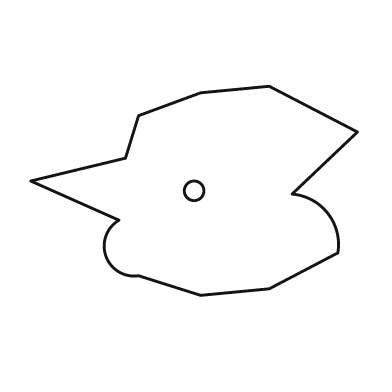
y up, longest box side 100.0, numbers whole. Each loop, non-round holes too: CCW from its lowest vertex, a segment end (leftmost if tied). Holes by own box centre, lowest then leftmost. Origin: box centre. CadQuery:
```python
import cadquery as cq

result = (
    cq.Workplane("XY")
    .moveTo(2.0, -32.0)
    .lineTo(23.0, -30.0)
    .lineTo(44.0, -19.0)
    .threePointArc((41.0, -7.0), (30.0, -1.0))
    .lineTo(50.0, 18.0)
    .lineTo(23.0, 32.0)
    .lineTo(2.0, 30.0)
    .lineTo(-17.0, 23.0)
    .lineTo(-21.0, 10.0)
    .lineTo(-50.0, 3.0)
    .lineTo(-23.0, -9.0)
    .threePointArc((-27.0, -20.0), (-17.0, -26.0))
    .close()
    .moveTo(0.0, 0.0)
    .circle(3.0)
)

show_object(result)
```